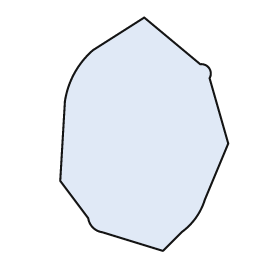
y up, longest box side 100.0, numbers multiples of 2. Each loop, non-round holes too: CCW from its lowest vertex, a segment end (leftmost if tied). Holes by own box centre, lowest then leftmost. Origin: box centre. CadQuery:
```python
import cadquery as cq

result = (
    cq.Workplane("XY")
    .moveTo(8.0, -50.0)
    .lineTo(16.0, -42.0)
    .threePointArc((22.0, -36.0), (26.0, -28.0))
    .lineTo(36.0, -4.0)
    .lineTo(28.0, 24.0)
    .threePointArc((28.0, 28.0), (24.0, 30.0))
    .lineTo(0.0, 50.0)
    .lineTo(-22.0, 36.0)
    .threePointArc((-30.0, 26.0), (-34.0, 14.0))
    .lineTo(-36.0, -20.0)
    .lineTo(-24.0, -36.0)
    .threePointArc((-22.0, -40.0), (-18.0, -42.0))
    .close()
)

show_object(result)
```